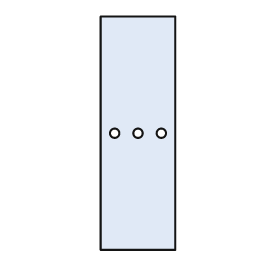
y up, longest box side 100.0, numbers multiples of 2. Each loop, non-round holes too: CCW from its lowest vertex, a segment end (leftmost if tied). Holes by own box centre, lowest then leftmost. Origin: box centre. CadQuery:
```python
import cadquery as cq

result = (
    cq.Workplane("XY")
    .moveTo(-16.0, -50.0)
    .lineTo(16.0, -50.0)
    .lineTo(16.0, 50.0)
    .lineTo(-16.0, 50.0)
    .close()
    .moveTo(-10.0, 0.0)
    .circle(2.0)
    .moveTo(0.0, 0.0)
    .circle(2.0)
    .moveTo(10.0, 0.0)
    .circle(2.0)
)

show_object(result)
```